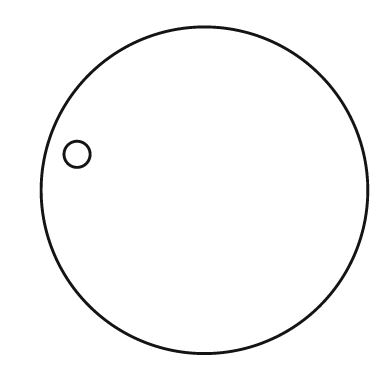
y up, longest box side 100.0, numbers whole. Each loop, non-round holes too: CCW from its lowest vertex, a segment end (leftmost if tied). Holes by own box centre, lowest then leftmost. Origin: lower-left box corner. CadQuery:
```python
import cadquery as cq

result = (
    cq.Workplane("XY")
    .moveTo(50.0, 50.0)
    .circle(50.0)
    .moveTo(11.0, 61.0)
    .circle(4.0)
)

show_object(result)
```